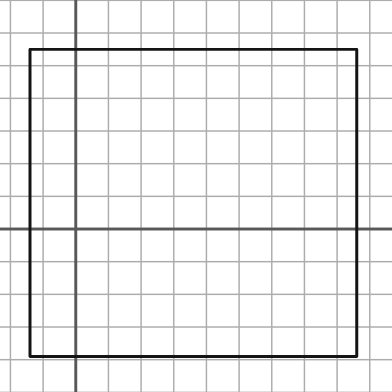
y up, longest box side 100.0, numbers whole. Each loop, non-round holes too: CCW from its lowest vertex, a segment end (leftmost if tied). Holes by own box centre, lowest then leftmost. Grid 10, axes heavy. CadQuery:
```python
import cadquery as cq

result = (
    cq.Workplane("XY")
    .moveTo(-14.0, -39.0)
    .lineTo(86.0, -39.0)
    .lineTo(86.0, 55.0)
    .lineTo(-14.0, 55.0)
    .close()
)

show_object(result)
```